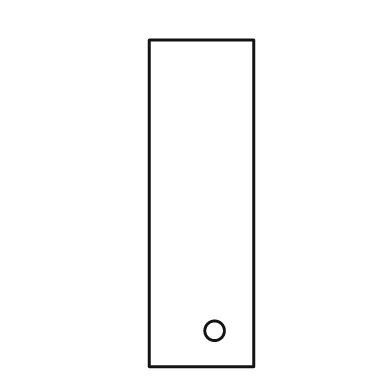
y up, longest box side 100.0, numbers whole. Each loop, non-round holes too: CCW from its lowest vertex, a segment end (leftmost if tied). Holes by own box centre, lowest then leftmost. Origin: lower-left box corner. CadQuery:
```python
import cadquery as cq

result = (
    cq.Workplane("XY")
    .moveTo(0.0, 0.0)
    .lineTo(32.0, 0.0)
    .lineTo(32.0, 100.0)
    .lineTo(0.0, 100.0)
    .close()
    .moveTo(20.0, 11.0)
    .circle(3.0)
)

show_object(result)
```